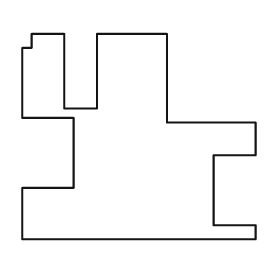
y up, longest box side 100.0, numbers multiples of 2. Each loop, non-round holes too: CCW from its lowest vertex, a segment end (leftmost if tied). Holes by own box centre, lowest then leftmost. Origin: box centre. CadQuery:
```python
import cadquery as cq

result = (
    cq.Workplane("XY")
    .moveTo(-50.0, -44.0)
    .lineTo(50.0, -44.0)
    .lineTo(50.0, -38.0)
    .lineTo(32.0, -38.0)
    .lineTo(32.0, -8.0)
    .lineTo(50.0, -8.0)
    .lineTo(50.0, 6.0)
    .lineTo(12.0, 6.0)
    .lineTo(12.0, 44.0)
    .lineTo(-18.0, 44.0)
    .lineTo(-18.0, 12.0)
    .lineTo(-32.0, 12.0)
    .lineTo(-32.0, 44.0)
    .lineTo(-46.0, 44.0)
    .lineTo(-46.0, 38.0)
    .lineTo(-50.0, 38.0)
    .lineTo(-50.0, 8.0)
    .lineTo(-28.0, 8.0)
    .lineTo(-28.0, -22.0)
    .lineTo(-50.0, -22.0)
    .close()
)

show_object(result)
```